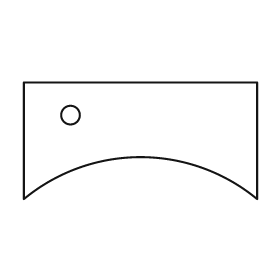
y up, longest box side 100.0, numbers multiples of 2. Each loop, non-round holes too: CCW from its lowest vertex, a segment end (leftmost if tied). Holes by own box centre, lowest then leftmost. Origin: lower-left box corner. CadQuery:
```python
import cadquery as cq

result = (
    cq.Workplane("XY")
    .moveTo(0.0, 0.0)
    .threePointArc((50.0, 18.0), (100.0, 0.0))
    .lineTo(100.0, 50.0)
    .lineTo(0.0, 50.0)
    .close()
    .moveTo(20.0, 36.0)
    .circle(4.0)
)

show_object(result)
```